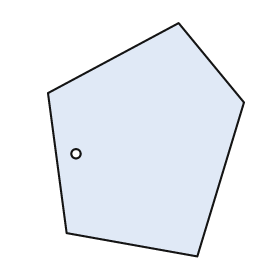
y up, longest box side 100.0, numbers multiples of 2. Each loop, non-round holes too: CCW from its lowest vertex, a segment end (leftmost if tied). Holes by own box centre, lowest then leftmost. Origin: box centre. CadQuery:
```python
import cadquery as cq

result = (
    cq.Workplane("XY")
    .moveTo(22.0, -50.0)
    .lineTo(42.0, 16.0)
    .lineTo(14.0, 50.0)
    .lineTo(-42.0, 20.0)
    .lineTo(-34.0, -40.0)
    .close()
    .moveTo(-30.0, -6.0)
    .circle(2.0)
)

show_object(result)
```